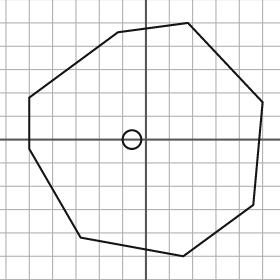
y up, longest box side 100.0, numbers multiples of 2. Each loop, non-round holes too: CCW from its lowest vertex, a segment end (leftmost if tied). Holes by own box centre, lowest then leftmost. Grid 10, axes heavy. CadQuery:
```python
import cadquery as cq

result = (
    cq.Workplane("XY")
    .moveTo(16.0, -50.0)
    .lineTo(46.0, -28.0)
    .lineTo(50.0, 16.0)
    .lineTo(18.0, 50.0)
    .lineTo(-12.0, 46.0)
    .lineTo(-50.0, 18.0)
    .lineTo(-50.0, -4.0)
    .lineTo(-28.0, -42.0)
    .close()
    .moveTo(-6.0, 0.0)
    .circle(4.0)
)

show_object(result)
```